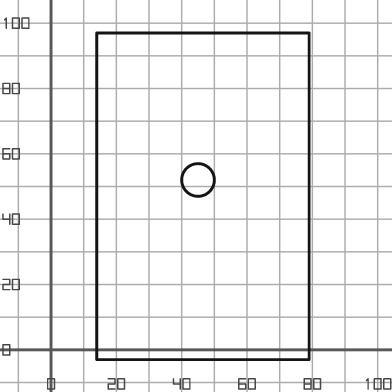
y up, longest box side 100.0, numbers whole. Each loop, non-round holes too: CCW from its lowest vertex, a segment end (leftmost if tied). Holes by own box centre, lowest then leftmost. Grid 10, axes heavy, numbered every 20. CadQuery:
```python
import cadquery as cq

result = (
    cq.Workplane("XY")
    .moveTo(14.0, -3.0)
    .lineTo(79.0, -3.0)
    .lineTo(79.0, 97.0)
    .lineTo(14.0, 97.0)
    .close()
    .moveTo(45.0, 52.0)
    .circle(5.0)
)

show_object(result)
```